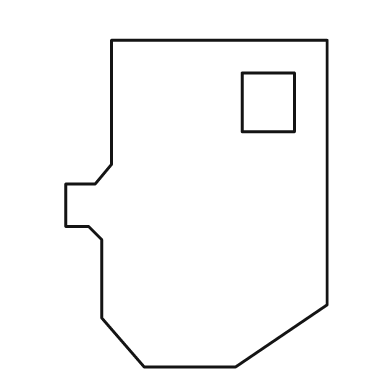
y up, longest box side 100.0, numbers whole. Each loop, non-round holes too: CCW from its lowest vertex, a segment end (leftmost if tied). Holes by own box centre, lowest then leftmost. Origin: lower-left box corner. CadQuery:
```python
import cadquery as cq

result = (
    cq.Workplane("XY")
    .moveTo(24.0, 0.0)
    .lineTo(52.0, 0.0)
    .lineTo(80.0, 19.0)
    .lineTo(80.0, 100.0)
    .lineTo(14.0, 100.0)
    .lineTo(14.0, 62.0)
    .lineTo(9.0, 56.0)
    .lineTo(0.0, 56.0)
    .lineTo(0.0, 43.0)
    .lineTo(7.0, 43.0)
    .lineTo(11.0, 39.0)
    .lineTo(11.0, 15.0)
    .close()
    .moveTo(54.0, 72.0)
    .lineTo(70.0, 72.0)
    .lineTo(70.0, 90.0)
    .lineTo(54.0, 90.0)
    .close()
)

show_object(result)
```